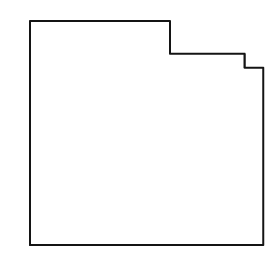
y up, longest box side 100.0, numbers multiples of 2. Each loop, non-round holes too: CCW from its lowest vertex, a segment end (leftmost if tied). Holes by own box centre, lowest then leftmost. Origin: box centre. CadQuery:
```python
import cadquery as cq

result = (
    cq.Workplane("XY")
    .moveTo(-50.0, -48.0)
    .lineTo(50.0, -48.0)
    .lineTo(50.0, 28.0)
    .lineTo(42.0, 28.0)
    .lineTo(42.0, 34.0)
    .lineTo(10.0, 34.0)
    .lineTo(10.0, 48.0)
    .lineTo(-50.0, 48.0)
    .close()
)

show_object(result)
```